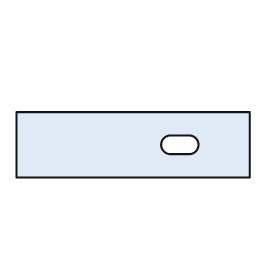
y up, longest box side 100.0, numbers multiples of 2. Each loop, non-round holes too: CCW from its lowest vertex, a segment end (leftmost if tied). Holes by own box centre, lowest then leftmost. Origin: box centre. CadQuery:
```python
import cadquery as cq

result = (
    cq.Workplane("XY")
    .moveTo(-50.0, -14.0)
    .lineTo(50.0, -14.0)
    .lineTo(50.0, 14.0)
    .lineTo(-50.0, 14.0)
    .close()
    .moveTo(16.0, -4.0)
    .lineTo(24.0, -4.0)
    .threePointArc((28.0, 0.0), (24.0, 4.0))
    .lineTo(16.0, 4.0)
    .threePointArc((12.0, 0.0), (16.0, -4.0))
    .close()
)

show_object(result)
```